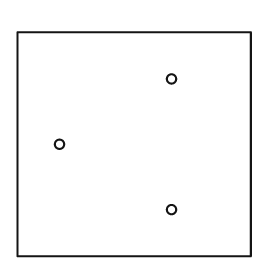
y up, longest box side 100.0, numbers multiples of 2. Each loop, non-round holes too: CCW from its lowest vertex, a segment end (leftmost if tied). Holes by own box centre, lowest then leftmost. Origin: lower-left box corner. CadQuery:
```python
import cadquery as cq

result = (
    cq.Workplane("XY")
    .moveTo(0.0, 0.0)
    .lineTo(100.0, 0.0)
    .lineTo(100.0, 96.0)
    .lineTo(0.0, 96.0)
    .close()
    .moveTo(66.0, 20.0)
    .circle(2.0)
    .moveTo(18.0, 48.0)
    .circle(2.0)
    .moveTo(66.0, 76.0)
    .circle(2.0)
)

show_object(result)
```